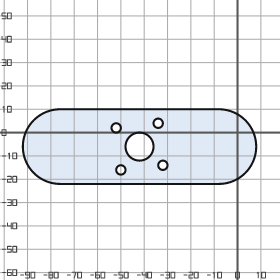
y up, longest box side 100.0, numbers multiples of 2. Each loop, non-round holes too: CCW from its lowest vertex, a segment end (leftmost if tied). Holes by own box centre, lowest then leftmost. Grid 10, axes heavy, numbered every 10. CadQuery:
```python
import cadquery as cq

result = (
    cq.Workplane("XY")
    .moveTo(-76.0, -22.0)
    .lineTo(-8.0, -22.0)
    .threePointArc((8.0, -6.0), (-8.0, 10.0))
    .lineTo(-76.0, 10.0)
    .threePointArc((-92.0, -6.0), (-76.0, -22.0))
    .close()
    .moveTo(-50.0, -16.0)
    .circle(2.0)
    .moveTo(-32.0, -14.0)
    .circle(2.0)
    .moveTo(-42.0, -6.0)
    .circle(6.0)
    .moveTo(-52.0, 2.0)
    .circle(2.0)
    .moveTo(-34.0, 4.0)
    .circle(2.0)
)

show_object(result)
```